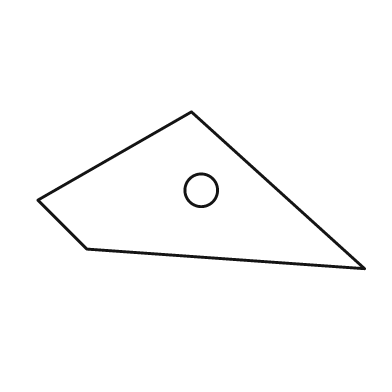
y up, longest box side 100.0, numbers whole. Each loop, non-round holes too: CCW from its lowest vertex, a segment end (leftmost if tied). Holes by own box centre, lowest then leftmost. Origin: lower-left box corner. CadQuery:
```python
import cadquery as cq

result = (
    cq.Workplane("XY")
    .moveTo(100.0, 0.0)
    .lineTo(47.0, 48.0)
    .lineTo(0.0, 21.0)
    .lineTo(15.0, 6.0)
    .close()
    .moveTo(50.0, 24.0)
    .circle(5.0)
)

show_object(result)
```